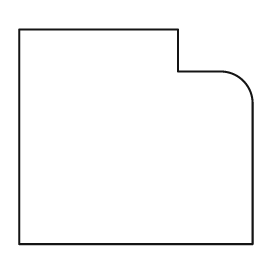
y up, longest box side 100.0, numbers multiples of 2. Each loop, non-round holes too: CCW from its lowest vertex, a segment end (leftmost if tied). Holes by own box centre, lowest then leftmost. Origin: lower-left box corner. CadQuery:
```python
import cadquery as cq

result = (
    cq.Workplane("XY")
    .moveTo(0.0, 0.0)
    .lineTo(100.0, 0.0)
    .lineTo(100.0, 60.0)
    .threePointArc((96.0, 70.0), (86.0, 74.0))
    .lineTo(68.0, 74.0)
    .lineTo(68.0, 92.0)
    .lineTo(0.0, 92.0)
    .close()
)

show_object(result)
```